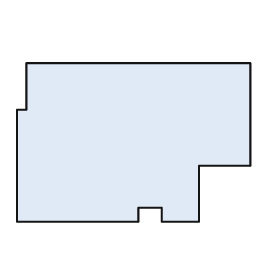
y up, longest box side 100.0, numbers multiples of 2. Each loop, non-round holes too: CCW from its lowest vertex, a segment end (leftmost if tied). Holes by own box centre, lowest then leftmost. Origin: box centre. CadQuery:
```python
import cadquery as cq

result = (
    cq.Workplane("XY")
    .moveTo(-50.0, -34.0)
    .lineTo(2.0, -34.0)
    .lineTo(2.0, -28.0)
    .lineTo(12.0, -28.0)
    .lineTo(12.0, -34.0)
    .lineTo(28.0, -34.0)
    .lineTo(28.0, -10.0)
    .lineTo(50.0, -10.0)
    .lineTo(50.0, 34.0)
    .lineTo(-46.0, 34.0)
    .lineTo(-46.0, 14.0)
    .lineTo(-50.0, 14.0)
    .close()
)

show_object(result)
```